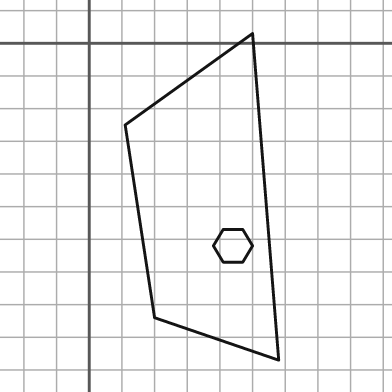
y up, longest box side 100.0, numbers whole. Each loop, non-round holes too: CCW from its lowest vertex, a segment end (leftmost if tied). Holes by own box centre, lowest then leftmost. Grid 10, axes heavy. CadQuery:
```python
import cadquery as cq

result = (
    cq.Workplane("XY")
    .moveTo(58.0, -97.0)
    .lineTo(50.0, 3.0)
    .lineTo(11.0, -25.0)
    .lineTo(20.0, -84.0)
    .close()
    .moveTo(41.0, -67.0)
    .lineTo(47.0, -67.0)
    .lineTo(50.0, -62.0)
    .lineTo(47.0, -57.0)
    .lineTo(41.0, -57.0)
    .lineTo(38.0, -62.0)
    .close()
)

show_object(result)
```